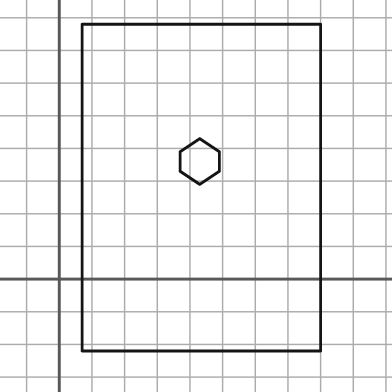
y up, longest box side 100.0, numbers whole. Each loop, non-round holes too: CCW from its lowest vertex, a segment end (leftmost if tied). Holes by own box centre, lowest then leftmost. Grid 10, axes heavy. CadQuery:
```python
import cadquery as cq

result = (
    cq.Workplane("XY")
    .moveTo(7.0, -22.0)
    .lineTo(80.0, -22.0)
    .lineTo(80.0, 78.0)
    .lineTo(7.0, 78.0)
    .close()
    .moveTo(43.0, 29.0)
    .lineTo(49.0, 33.0)
    .lineTo(49.0, 39.0)
    .lineTo(43.0, 43.0)
    .lineTo(37.0, 39.0)
    .lineTo(37.0, 33.0)
    .close()
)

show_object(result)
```